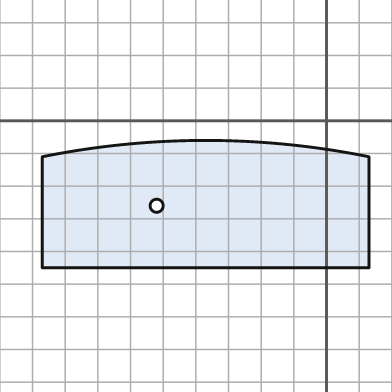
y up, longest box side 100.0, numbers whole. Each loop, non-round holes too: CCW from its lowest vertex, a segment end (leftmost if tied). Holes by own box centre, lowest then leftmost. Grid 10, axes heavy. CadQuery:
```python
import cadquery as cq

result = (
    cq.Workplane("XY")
    .moveTo(-87.0, -45.0)
    .lineTo(13.0, -45.0)
    .lineTo(13.0, -11.0)
    .threePointArc((-37.0, -6.0), (-87.0, -11.0))
    .close()
    .moveTo(-52.0, -26.0)
    .circle(2.0)
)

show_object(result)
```